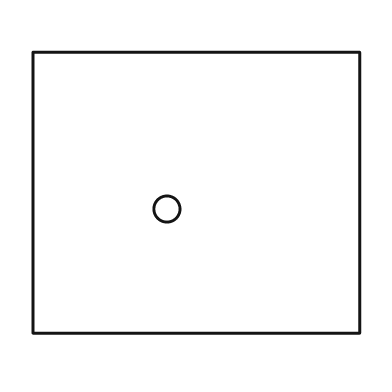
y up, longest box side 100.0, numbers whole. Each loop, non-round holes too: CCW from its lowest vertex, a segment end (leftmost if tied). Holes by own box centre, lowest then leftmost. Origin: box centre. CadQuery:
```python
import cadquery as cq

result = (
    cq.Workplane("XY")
    .moveTo(-50.0, -43.0)
    .lineTo(50.0, -43.0)
    .lineTo(50.0, 43.0)
    .lineTo(-50.0, 43.0)
    .close()
    .moveTo(-9.0, -5.0)
    .circle(4.0)
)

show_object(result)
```